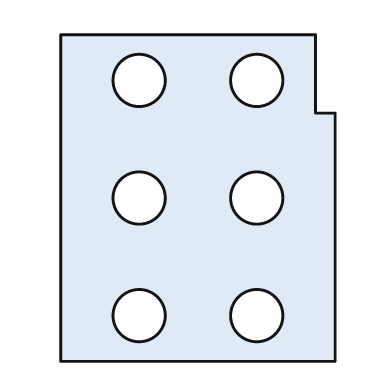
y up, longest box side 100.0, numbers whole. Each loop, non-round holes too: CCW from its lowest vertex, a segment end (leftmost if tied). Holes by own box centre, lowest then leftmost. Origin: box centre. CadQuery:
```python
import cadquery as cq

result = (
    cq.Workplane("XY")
    .moveTo(-42.0, -50.0)
    .lineTo(42.0, -50.0)
    .lineTo(42.0, 26.0)
    .lineTo(36.0, 26.0)
    .lineTo(36.0, 50.0)
    .lineTo(-42.0, 50.0)
    .close()
    .moveTo(-18.0, -36.0)
    .circle(8.0)
    .moveTo(18.0, -36.0)
    .circle(8.0)
    .moveTo(-18.0, 0.0)
    .circle(8.0)
    .moveTo(18.0, 0.0)
    .circle(8.0)
    .moveTo(-18.0, 36.0)
    .circle(8.0)
    .moveTo(18.0, 36.0)
    .circle(8.0)
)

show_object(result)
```